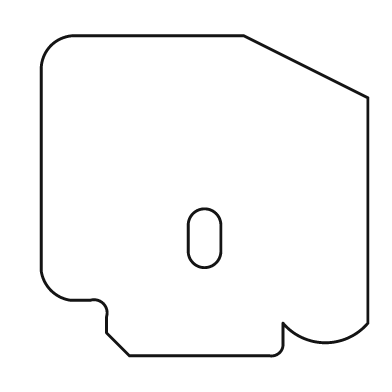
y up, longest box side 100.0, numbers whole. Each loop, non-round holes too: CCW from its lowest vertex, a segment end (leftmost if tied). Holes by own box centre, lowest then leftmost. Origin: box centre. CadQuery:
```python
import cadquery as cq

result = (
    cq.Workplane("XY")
    .moveTo(-23.0, -49.0)
    .lineTo(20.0, -49.0)
    .threePointArc((23.0, -48.0), (24.0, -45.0))
    .lineTo(24.0, -39.0)
    .threePointArc((37.0, -45.0), (50.0, -39.0))
    .lineTo(50.0, 30.0)
    .lineTo(12.0, 49.0)
    .lineTo(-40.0, 49.0)
    .threePointArc((-47.0, 46.0), (-50.0, 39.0))
    .lineTo(-50.0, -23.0)
    .threePointArc((-47.0, -29.0), (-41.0, -32.0))
    .lineTo(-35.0, -32.0)
    .threePointArc((-31.0, -33.0), (-30.0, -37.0))
    .lineTo(-30.0, -42.0)
    .close()
    .moveTo(-5.0, -17.0)
    .threePointArc((0.0, -22.0), (5.0, -17.0))
    .lineTo(5.0, -9.0)
    .threePointArc((0.0, -4.0), (-5.0, -9.0))
    .close()
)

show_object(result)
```